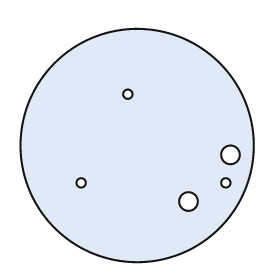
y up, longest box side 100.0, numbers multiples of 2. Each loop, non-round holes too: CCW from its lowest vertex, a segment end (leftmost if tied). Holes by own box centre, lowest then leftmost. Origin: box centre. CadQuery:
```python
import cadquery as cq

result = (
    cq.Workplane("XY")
    .moveTo(0.0, 0.0)
    .circle(50.0)
    .moveTo(22.0, -24.0)
    .circle(4.0)
    .moveTo(-24.0, -16.0)
    .circle(2.0)
    .moveTo(38.0, -16.0)
    .circle(2.0)
    .moveTo(40.0, -4.0)
    .circle(4.0)
    .moveTo(-4.0, 22.0)
    .circle(2.0)
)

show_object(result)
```